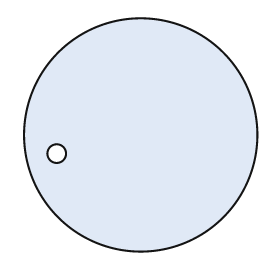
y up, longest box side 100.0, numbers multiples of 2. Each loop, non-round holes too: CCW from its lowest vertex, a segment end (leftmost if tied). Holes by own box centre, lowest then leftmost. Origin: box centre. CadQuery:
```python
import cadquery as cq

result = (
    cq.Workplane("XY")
    .moveTo(0.0, 0.0)
    .circle(50.0)
    .moveTo(-36.0, -8.0)
    .circle(4.0)
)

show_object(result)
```